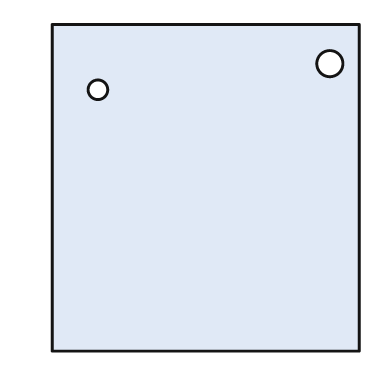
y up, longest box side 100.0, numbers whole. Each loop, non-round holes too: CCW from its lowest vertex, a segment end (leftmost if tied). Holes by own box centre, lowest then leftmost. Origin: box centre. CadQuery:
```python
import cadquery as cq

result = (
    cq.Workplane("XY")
    .moveTo(-47.0, -50.0)
    .lineTo(47.0, -50.0)
    .lineTo(47.0, 50.0)
    .lineTo(-47.0, 50.0)
    .close()
    .moveTo(-33.0, 30.0)
    .circle(3.0)
    .moveTo(38.0, 38.0)
    .circle(4.0)
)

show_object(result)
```